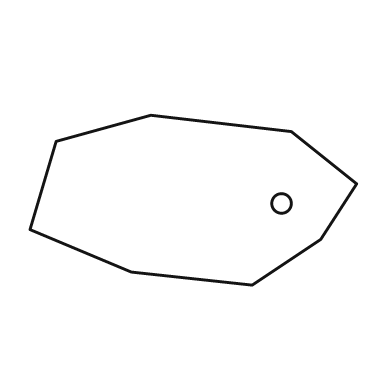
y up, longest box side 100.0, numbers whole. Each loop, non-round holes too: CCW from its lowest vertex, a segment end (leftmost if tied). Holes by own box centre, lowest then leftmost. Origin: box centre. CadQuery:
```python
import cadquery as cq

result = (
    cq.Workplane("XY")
    .moveTo(18.0, -26.0)
    .lineTo(39.0, -12.0)
    .lineTo(50.0, 5.0)
    .lineTo(30.0, 21.0)
    .lineTo(-13.0, 26.0)
    .lineTo(-42.0, 18.0)
    .lineTo(-50.0, -9.0)
    .lineTo(-19.0, -22.0)
    .close()
    .moveTo(27.0, -1.0)
    .circle(3.0)
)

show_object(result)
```